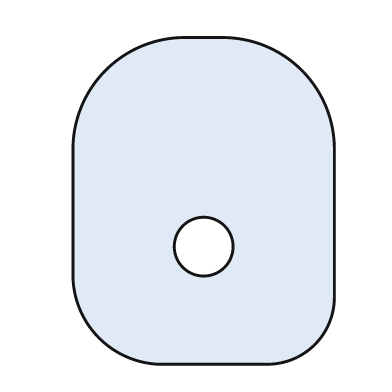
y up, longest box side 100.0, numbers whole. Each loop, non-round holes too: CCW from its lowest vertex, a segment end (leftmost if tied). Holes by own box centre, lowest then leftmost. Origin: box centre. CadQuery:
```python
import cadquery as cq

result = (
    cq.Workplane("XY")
    .moveTo(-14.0, -50.0)
    .lineTo(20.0, -50.0)
    .threePointArc((34.0, -44.0), (40.0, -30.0))
    .lineTo(40.0, 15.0)
    .threePointArc((30.0, 40.0), (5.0, 50.0))
    .lineTo(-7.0, 50.0)
    .threePointArc((-30.0, 40.0), (-40.0, 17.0))
    .lineTo(-40.0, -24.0)
    .threePointArc((-32.0, -42.0), (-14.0, -50.0))
    .close()
    .moveTo(0.0, -14.0)
    .circle(9.0)
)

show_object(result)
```